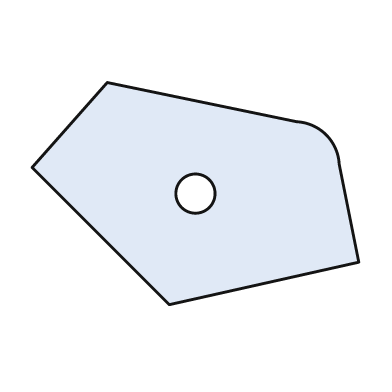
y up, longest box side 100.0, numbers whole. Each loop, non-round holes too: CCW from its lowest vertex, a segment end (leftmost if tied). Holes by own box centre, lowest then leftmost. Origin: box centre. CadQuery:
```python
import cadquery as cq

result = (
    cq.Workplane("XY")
    .moveTo(-8.0, -34.0)
    .lineTo(50.0, -21.0)
    .lineTo(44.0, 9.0)
    .threePointArc((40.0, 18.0), (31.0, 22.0))
    .lineTo(-27.0, 34.0)
    .lineTo(-50.0, 8.0)
    .close()
    .moveTo(0.0, 0.0)
    .circle(6.0)
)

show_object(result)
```